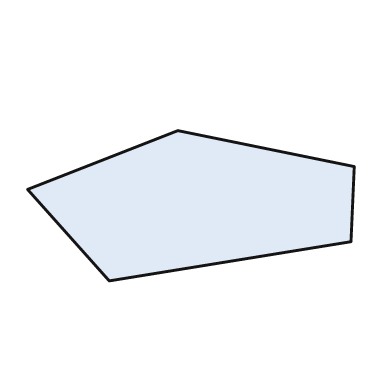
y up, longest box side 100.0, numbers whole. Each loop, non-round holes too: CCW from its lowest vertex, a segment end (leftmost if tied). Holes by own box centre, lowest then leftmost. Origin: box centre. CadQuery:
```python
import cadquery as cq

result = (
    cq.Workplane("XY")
    .moveTo(-25.0, -23.0)
    .lineTo(49.0, -11.0)
    .lineTo(50.0, 12.0)
    .lineTo(-4.0, 23.0)
    .lineTo(-50.0, 5.0)
    .close()
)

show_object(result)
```